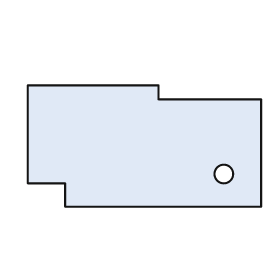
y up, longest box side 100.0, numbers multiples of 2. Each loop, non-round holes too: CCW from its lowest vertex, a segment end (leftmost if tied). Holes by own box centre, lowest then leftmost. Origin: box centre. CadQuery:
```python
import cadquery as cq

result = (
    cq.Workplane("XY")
    .moveTo(-34.0, -26.0)
    .lineTo(50.0, -26.0)
    .lineTo(50.0, 20.0)
    .lineTo(6.0, 20.0)
    .lineTo(6.0, 26.0)
    .lineTo(-50.0, 26.0)
    .lineTo(-50.0, -16.0)
    .lineTo(-34.0, -16.0)
    .close()
    .moveTo(34.0, -12.0)
    .circle(4.0)
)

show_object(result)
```